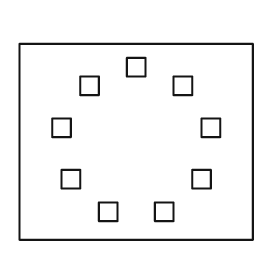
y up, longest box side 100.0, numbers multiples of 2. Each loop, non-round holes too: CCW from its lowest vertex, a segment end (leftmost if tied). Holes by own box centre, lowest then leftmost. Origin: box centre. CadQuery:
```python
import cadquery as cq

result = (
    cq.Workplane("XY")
    .moveTo(-50.0, -42.0)
    .lineTo(50.0, -42.0)
    .lineTo(50.0, 42.0)
    .lineTo(-50.0, 42.0)
    .close()
    .moveTo(-16.0, -34.0)
    .lineTo(-8.0, -34.0)
    .lineTo(-8.0, -26.0)
    .lineTo(-16.0, -26.0)
    .close()
    .moveTo(8.0, -34.0)
    .lineTo(16.0, -34.0)
    .lineTo(16.0, -26.0)
    .lineTo(8.0, -26.0)
    .close()
    .moveTo(-32.0, -20.0)
    .lineTo(-24.0, -20.0)
    .lineTo(-24.0, -12.0)
    .lineTo(-32.0, -12.0)
    .close()
    .moveTo(24.0, -20.0)
    .lineTo(32.0, -20.0)
    .lineTo(32.0, -12.0)
    .lineTo(24.0, -12.0)
    .close()
    .moveTo(-36.0, 2.0)
    .lineTo(-28.0, 2.0)
    .lineTo(-28.0, 10.0)
    .lineTo(-36.0, 10.0)
    .close()
    .moveTo(28.0, 2.0)
    .lineTo(36.0, 2.0)
    .lineTo(36.0, 10.0)
    .lineTo(28.0, 10.0)
    .close()
    .moveTo(-24.0, 20.0)
    .lineTo(-16.0, 20.0)
    .lineTo(-16.0, 28.0)
    .lineTo(-24.0, 28.0)
    .close()
    .moveTo(16.0, 20.0)
    .lineTo(24.0, 20.0)
    .lineTo(24.0, 28.0)
    .lineTo(16.0, 28.0)
    .close()
    .moveTo(-4.0, 28.0)
    .lineTo(4.0, 28.0)
    .lineTo(4.0, 36.0)
    .lineTo(-4.0, 36.0)
    .close()
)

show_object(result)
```